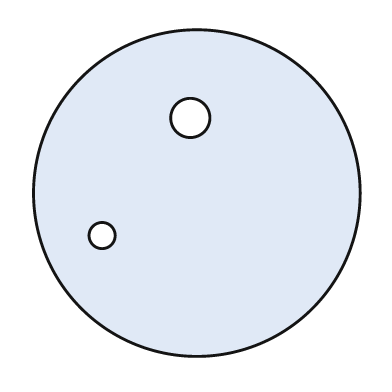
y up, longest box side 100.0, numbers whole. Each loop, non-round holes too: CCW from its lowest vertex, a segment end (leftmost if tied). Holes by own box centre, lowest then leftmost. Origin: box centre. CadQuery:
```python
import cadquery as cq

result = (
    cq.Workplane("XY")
    .moveTo(0.0, 0.0)
    .circle(50.0)
    .moveTo(-29.0, -13.0)
    .circle(4.0)
    .moveTo(-2.0, 23.0)
    .circle(6.0)
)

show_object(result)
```